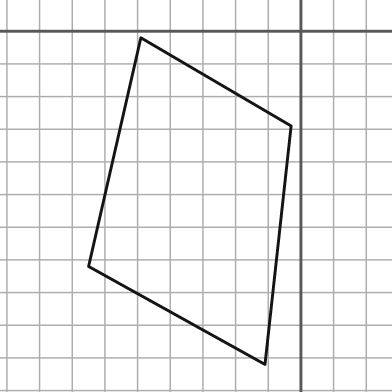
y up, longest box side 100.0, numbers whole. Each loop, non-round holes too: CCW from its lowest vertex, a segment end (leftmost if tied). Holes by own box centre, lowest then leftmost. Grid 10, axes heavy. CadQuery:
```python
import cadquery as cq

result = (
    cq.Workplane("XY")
    .moveTo(-11.0, -102.0)
    .lineTo(-3.0, -29.0)
    .lineTo(-49.0, -2.0)
    .lineTo(-65.0, -72.0)
    .close()
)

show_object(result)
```